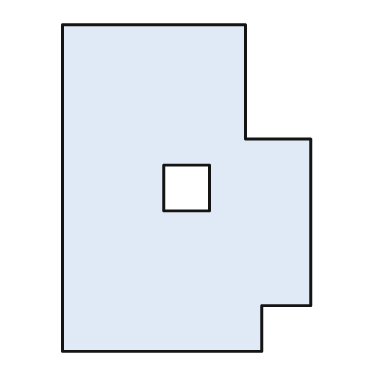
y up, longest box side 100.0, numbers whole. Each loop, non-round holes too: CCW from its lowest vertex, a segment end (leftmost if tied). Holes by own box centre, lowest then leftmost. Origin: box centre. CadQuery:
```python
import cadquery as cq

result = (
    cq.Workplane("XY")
    .moveTo(-38.0, -50.0)
    .lineTo(23.0, -50.0)
    .lineTo(23.0, -36.0)
    .lineTo(38.0, -36.0)
    .lineTo(38.0, 15.0)
    .lineTo(18.0, 15.0)
    .lineTo(18.0, 50.0)
    .lineTo(-38.0, 50.0)
    .close()
    .moveTo(-7.0, -7.0)
    .lineTo(7.0, -7.0)
    .lineTo(7.0, 7.0)
    .lineTo(-7.0, 7.0)
    .close()
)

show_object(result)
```